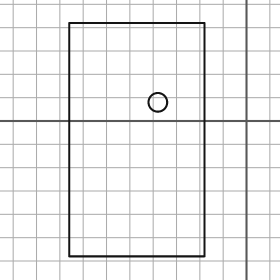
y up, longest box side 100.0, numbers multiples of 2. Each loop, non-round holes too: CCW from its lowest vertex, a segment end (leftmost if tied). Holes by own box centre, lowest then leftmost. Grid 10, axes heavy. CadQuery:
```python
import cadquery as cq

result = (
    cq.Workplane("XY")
    .moveTo(-76.0, -58.0)
    .lineTo(-18.0, -58.0)
    .lineTo(-18.0, 42.0)
    .lineTo(-76.0, 42.0)
    .close()
    .moveTo(-38.0, 8.0)
    .circle(4.0)
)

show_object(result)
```